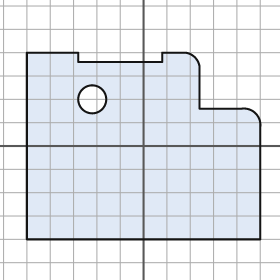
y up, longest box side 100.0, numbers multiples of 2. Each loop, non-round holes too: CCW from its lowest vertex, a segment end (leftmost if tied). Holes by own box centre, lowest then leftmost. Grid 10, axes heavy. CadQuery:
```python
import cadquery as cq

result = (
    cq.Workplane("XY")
    .moveTo(-50.0, -40.0)
    .lineTo(50.0, -40.0)
    .lineTo(50.0, 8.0)
    .threePointArc((48.0, 14.0), (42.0, 16.0))
    .lineTo(24.0, 16.0)
    .lineTo(24.0, 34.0)
    .threePointArc((22.0, 38.0), (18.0, 40.0))
    .lineTo(8.0, 40.0)
    .lineTo(8.0, 36.0)
    .lineTo(-28.0, 36.0)
    .lineTo(-28.0, 40.0)
    .lineTo(-50.0, 40.0)
    .close()
    .moveTo(-22.0, 20.0)
    .circle(6.0)
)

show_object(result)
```